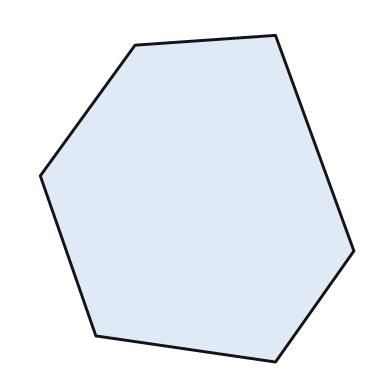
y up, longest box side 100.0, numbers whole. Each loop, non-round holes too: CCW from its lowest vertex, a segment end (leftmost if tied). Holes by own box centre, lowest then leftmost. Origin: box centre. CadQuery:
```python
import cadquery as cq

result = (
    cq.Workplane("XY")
    .moveTo(24.0, -50.0)
    .lineTo(48.0, -16.0)
    .lineTo(24.0, 50.0)
    .lineTo(-19.0, 47.0)
    .lineTo(-48.0, 7.0)
    .lineTo(-31.0, -42.0)
    .close()
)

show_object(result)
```